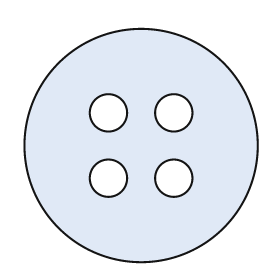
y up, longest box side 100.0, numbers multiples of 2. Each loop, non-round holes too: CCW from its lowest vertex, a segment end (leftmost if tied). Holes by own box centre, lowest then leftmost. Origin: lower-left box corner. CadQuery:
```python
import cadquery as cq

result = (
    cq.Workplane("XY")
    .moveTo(50.0, 50.0)
    .circle(50.0)
    .moveTo(36.0, 36.0)
    .circle(8.0)
    .moveTo(64.0, 36.0)
    .circle(8.0)
    .moveTo(36.0, 64.0)
    .circle(8.0)
    .moveTo(64.0, 64.0)
    .circle(8.0)
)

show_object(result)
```